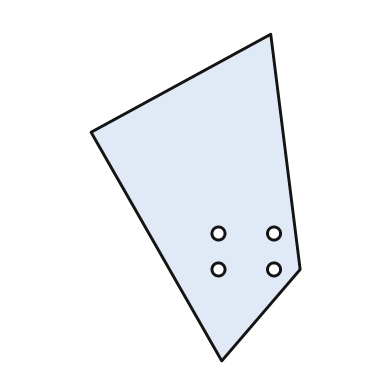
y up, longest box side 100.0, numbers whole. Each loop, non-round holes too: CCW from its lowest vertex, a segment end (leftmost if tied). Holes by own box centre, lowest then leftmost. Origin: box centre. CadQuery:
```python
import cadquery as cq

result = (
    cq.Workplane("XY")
    .moveTo(8.0, -50.0)
    .lineTo(32.0, -22.0)
    .lineTo(23.0, 50.0)
    .lineTo(-32.0, 20.0)
    .close()
    .moveTo(7.0, -22.0)
    .circle(2.0)
    .moveTo(24.0, -22.0)
    .circle(2.0)
    .moveTo(7.0, -11.0)
    .circle(2.0)
    .moveTo(24.0, -11.0)
    .circle(2.0)
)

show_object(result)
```